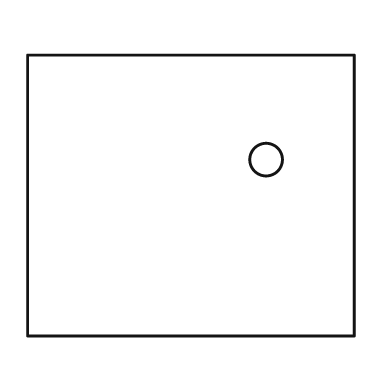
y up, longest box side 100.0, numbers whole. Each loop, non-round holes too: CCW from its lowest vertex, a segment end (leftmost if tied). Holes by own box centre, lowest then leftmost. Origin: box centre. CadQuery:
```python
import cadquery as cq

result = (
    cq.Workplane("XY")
    .moveTo(-50.0, -43.0)
    .lineTo(50.0, -43.0)
    .lineTo(50.0, 43.0)
    .lineTo(-50.0, 43.0)
    .close()
    .moveTo(23.0, 11.0)
    .circle(5.0)
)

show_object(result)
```